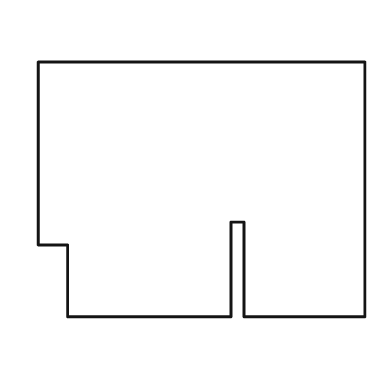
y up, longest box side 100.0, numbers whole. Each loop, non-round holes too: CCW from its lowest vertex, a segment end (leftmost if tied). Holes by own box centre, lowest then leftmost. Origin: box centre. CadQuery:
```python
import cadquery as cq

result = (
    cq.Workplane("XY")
    .moveTo(-41.0, -39.0)
    .lineTo(9.0, -39.0)
    .lineTo(9.0, -10.0)
    .lineTo(13.0, -10.0)
    .lineTo(13.0, -39.0)
    .lineTo(50.0, -39.0)
    .lineTo(50.0, 39.0)
    .lineTo(-50.0, 39.0)
    .lineTo(-50.0, -17.0)
    .lineTo(-41.0, -17.0)
    .close()
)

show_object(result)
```